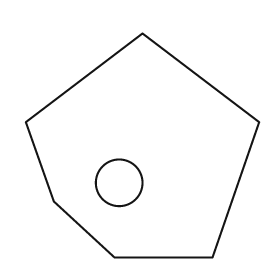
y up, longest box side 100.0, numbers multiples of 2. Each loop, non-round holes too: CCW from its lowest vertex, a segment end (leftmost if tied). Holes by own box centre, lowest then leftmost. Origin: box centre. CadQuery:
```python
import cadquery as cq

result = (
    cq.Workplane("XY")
    .moveTo(-12.0, -48.0)
    .lineTo(30.0, -48.0)
    .lineTo(50.0, 10.0)
    .lineTo(0.0, 48.0)
    .lineTo(-50.0, 10.0)
    .lineTo(-38.0, -24.0)
    .close()
    .moveTo(-10.0, -16.0)
    .circle(10.0)
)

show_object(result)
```